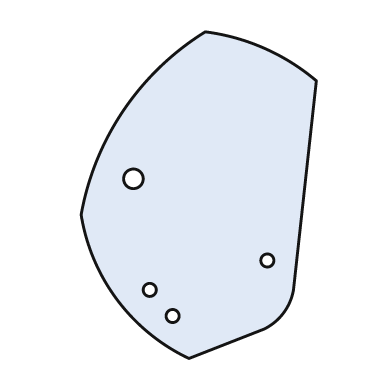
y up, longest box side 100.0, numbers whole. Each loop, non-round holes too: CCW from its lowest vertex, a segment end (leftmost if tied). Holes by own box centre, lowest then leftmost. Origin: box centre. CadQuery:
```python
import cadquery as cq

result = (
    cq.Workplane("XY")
    .moveTo(-3.0, -50.0)
    .lineTo(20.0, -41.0)
    .threePointArc((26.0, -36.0), (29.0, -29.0))
    .lineTo(36.0, 35.0)
    .threePointArc((20.0, 45.0), (2.0, 50.0))
    .threePointArc((-23.0, 26.0), (-36.0, -6.0))
    .threePointArc((-25.0, -32.0), (-3.0, -50.0))
    .close()
    .moveTo(-8.0, -37.0)
    .circle(2.0)
    .moveTo(-15.0, -29.0)
    .circle(2.0)
    .moveTo(21.0, -20.0)
    .circle(2.0)
    .moveTo(-20.0, 5.0)
    .circle(3.0)
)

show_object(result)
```